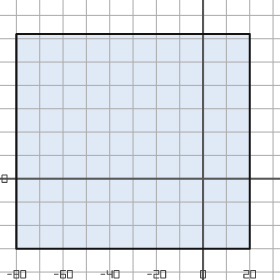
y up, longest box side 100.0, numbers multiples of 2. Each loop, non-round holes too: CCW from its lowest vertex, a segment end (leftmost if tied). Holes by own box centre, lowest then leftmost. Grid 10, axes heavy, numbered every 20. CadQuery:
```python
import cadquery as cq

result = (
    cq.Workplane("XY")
    .moveTo(-80.0, -30.0)
    .lineTo(20.0, -30.0)
    .lineTo(20.0, 62.0)
    .lineTo(-80.0, 62.0)
    .close()
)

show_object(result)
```